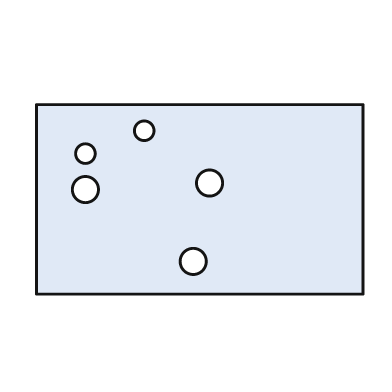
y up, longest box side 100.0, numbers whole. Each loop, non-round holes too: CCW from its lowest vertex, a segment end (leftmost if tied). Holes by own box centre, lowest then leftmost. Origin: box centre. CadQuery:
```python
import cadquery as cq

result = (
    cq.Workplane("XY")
    .moveTo(-50.0, -29.0)
    .lineTo(50.0, -29.0)
    .lineTo(50.0, 29.0)
    .lineTo(-50.0, 29.0)
    .close()
    .moveTo(-2.0, -19.0)
    .circle(4.0)
    .moveTo(-35.0, 3.0)
    .circle(4.0)
    .moveTo(3.0, 5.0)
    .circle(4.0)
    .moveTo(-35.0, 14.0)
    .circle(3.0)
    .moveTo(-17.0, 21.0)
    .circle(3.0)
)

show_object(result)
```